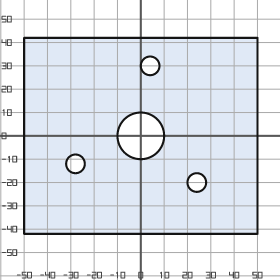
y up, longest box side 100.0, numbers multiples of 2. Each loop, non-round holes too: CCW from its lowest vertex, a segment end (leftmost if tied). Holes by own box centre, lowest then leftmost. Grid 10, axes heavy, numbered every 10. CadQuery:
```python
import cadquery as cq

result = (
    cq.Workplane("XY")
    .moveTo(-50.0, -42.0)
    .lineTo(50.0, -42.0)
    .lineTo(50.0, 42.0)
    .lineTo(-50.0, 42.0)
    .close()
    .moveTo(24.0, -20.0)
    .circle(4.0)
    .moveTo(-28.0, -12.0)
    .circle(4.0)
    .moveTo(0.0, 0.0)
    .circle(10.0)
    .moveTo(4.0, 30.0)
    .circle(4.0)
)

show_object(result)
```